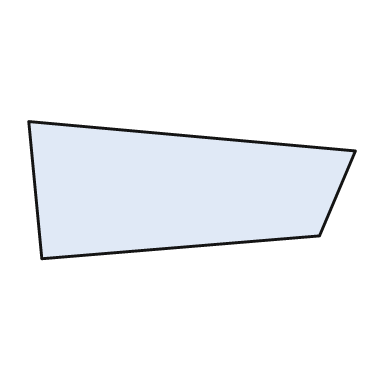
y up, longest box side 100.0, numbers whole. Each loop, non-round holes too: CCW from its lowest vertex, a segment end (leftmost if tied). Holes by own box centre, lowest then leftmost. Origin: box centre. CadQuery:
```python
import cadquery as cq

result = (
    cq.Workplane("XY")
    .moveTo(-46.0, -21.0)
    .lineTo(39.0, -14.0)
    .lineTo(50.0, 12.0)
    .lineTo(-50.0, 21.0)
    .close()
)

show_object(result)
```